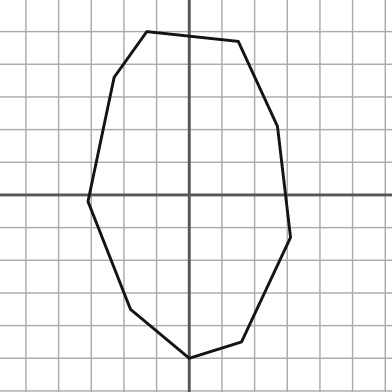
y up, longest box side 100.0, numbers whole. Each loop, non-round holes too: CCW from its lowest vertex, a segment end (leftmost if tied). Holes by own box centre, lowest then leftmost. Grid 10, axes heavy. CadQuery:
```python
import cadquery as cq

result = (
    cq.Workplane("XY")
    .moveTo(0.0, -50.0)
    .lineTo(16.0, -45.0)
    .lineTo(31.0, -13.0)
    .lineTo(27.0, 21.0)
    .lineTo(15.0, 47.0)
    .lineTo(-13.0, 50.0)
    .lineTo(-23.0, 36.0)
    .lineTo(-31.0, -2.0)
    .lineTo(-18.0, -35.0)
    .close()
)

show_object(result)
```